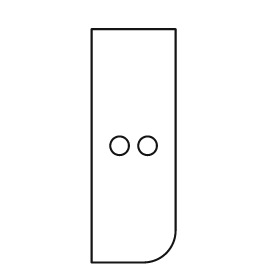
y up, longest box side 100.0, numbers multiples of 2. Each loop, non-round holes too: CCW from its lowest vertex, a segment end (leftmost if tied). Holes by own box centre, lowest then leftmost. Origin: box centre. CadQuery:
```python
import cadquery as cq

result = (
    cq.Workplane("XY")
    .moveTo(-18.0, -50.0)
    .lineTo(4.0, -50.0)
    .threePointArc((14.0, -46.0), (18.0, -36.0))
    .lineTo(18.0, 50.0)
    .lineTo(-18.0, 50.0)
    .close()
    .moveTo(-6.0, 0.0)
    .circle(4.0)
    .moveTo(6.0, 0.0)
    .circle(4.0)
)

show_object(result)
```